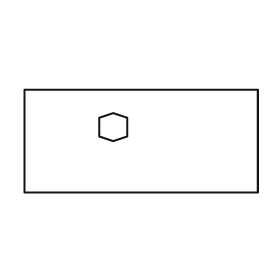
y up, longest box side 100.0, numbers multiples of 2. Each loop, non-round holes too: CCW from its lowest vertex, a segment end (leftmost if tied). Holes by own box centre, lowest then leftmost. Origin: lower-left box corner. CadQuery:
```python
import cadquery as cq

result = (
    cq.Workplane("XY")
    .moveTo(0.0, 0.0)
    .lineTo(100.0, 0.0)
    .lineTo(100.0, 44.0)
    .lineTo(0.0, 44.0)
    .close()
    .moveTo(38.0, 22.0)
    .lineTo(44.0, 24.0)
    .lineTo(44.0, 32.0)
    .lineTo(38.0, 34.0)
    .lineTo(32.0, 32.0)
    .lineTo(32.0, 24.0)
    .close()
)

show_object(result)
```